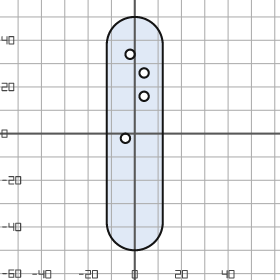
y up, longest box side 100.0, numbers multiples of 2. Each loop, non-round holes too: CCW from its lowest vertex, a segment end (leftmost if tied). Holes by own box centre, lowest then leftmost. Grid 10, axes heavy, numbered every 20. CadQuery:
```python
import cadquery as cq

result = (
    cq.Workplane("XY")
    .moveTo(-12.0, -38.0)
    .threePointArc((0.0, -50.0), (12.0, -38.0))
    .lineTo(12.0, 38.0)
    .threePointArc((0.0, 50.0), (-12.0, 38.0))
    .close()
    .moveTo(-4.0, -2.0)
    .circle(2.0)
    .moveTo(4.0, 16.0)
    .circle(2.0)
    .moveTo(4.0, 26.0)
    .circle(2.0)
    .moveTo(-2.0, 34.0)
    .circle(2.0)
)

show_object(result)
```